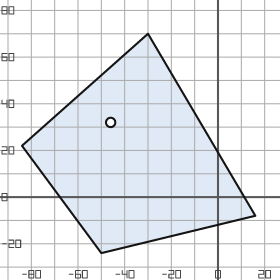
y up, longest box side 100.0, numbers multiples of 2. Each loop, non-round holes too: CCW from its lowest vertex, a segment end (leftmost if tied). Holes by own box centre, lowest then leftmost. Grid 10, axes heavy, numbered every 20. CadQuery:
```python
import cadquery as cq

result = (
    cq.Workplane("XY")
    .moveTo(-50.0, -24.0)
    .lineTo(16.0, -8.0)
    .lineTo(-30.0, 70.0)
    .lineTo(-84.0, 22.0)
    .close()
    .moveTo(-46.0, 32.0)
    .circle(2.0)
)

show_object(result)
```